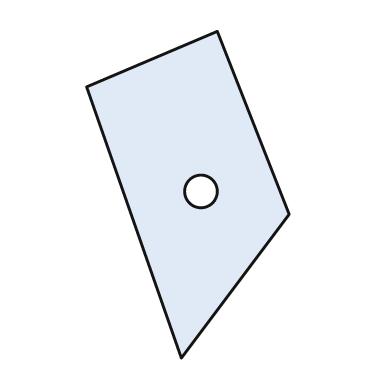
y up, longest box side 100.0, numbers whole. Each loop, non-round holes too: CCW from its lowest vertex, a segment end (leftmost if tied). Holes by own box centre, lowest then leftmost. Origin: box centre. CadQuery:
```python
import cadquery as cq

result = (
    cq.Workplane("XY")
    .moveTo(-2.0, -50.0)
    .lineTo(31.0, -6.0)
    .lineTo(9.0, 50.0)
    .lineTo(-31.0, 33.0)
    .close()
    .moveTo(4.0, 1.0)
    .circle(5.0)
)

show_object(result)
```